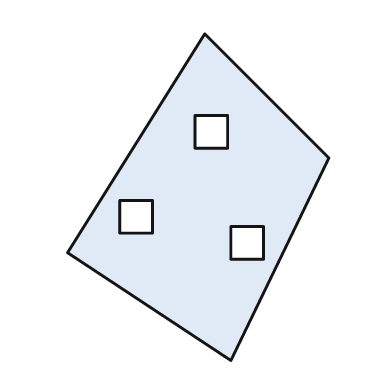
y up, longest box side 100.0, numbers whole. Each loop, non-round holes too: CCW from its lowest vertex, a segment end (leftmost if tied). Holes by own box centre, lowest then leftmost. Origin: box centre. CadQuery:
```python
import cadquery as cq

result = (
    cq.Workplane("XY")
    .moveTo(10.0, -50.0)
    .lineTo(40.0, 12.0)
    .lineTo(2.0, 50.0)
    .lineTo(-40.0, -17.0)
    .close()
    .moveTo(10.0, -19.0)
    .lineTo(20.0, -19.0)
    .lineTo(20.0, -9.0)
    .lineTo(10.0, -9.0)
    .close()
    .moveTo(-24.0, -11.0)
    .lineTo(-14.0, -11.0)
    .lineTo(-14.0, -1.0)
    .lineTo(-24.0, -1.0)
    .close()
    .moveTo(-1.0, 15.0)
    .lineTo(9.0, 15.0)
    .lineTo(9.0, 25.0)
    .lineTo(-1.0, 25.0)
    .close()
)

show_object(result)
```